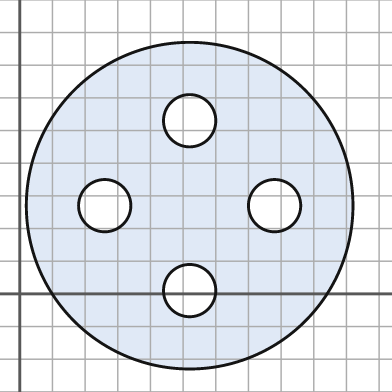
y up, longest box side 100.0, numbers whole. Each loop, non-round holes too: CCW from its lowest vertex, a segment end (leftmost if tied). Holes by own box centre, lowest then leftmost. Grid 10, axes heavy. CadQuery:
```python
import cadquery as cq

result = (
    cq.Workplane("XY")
    .moveTo(52.0, 27.0)
    .circle(50.0)
    .moveTo(52.0, 1.0)
    .circle(8.0)
    .moveTo(26.0, 27.0)
    .circle(8.0)
    .moveTo(78.0, 27.0)
    .circle(8.0)
    .moveTo(52.0, 53.0)
    .circle(8.0)
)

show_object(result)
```